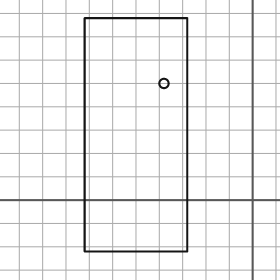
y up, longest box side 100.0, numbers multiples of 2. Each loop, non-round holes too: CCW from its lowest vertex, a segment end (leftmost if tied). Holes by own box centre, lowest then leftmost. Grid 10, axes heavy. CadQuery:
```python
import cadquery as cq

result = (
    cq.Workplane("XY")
    .moveTo(-72.0, -22.0)
    .lineTo(-28.0, -22.0)
    .lineTo(-28.0, 78.0)
    .lineTo(-72.0, 78.0)
    .close()
    .moveTo(-38.0, 50.0)
    .circle(2.0)
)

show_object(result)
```